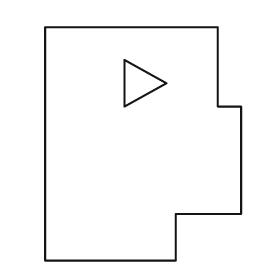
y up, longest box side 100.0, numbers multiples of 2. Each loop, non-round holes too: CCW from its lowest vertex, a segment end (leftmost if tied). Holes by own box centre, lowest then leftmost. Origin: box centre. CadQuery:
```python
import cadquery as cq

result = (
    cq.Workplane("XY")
    .moveTo(-42.0, -50.0)
    .lineTo(14.0, -50.0)
    .lineTo(14.0, -30.0)
    .lineTo(42.0, -30.0)
    .lineTo(42.0, 16.0)
    .lineTo(32.0, 16.0)
    .lineTo(32.0, 50.0)
    .lineTo(-42.0, 50.0)
    .close()
    .moveTo(-8.0, 16.0)
    .lineTo(10.0, 26.0)
    .lineTo(-8.0, 36.0)
    .close()
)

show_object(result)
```